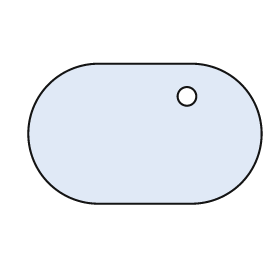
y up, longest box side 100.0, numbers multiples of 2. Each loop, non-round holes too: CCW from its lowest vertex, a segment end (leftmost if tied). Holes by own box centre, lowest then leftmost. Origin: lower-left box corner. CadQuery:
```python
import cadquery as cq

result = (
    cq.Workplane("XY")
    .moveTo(30.0, 0.0)
    .lineTo(70.0, 0.0)
    .threePointArc((100.0, 30.0), (70.0, 60.0))
    .lineTo(30.0, 60.0)
    .threePointArc((0.0, 30.0), (30.0, 0.0))
    .close()
    .moveTo(68.0, 46.0)
    .circle(4.0)
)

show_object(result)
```